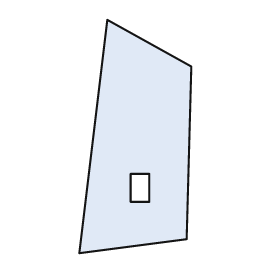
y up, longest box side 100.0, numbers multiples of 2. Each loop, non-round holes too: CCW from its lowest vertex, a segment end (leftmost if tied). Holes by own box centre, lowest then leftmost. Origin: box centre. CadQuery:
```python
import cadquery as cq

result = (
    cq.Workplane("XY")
    .moveTo(-24.0, -50.0)
    .lineTo(22.0, -44.0)
    .lineTo(24.0, 30.0)
    .lineTo(-12.0, 50.0)
    .close()
    .moveTo(-2.0, -28.0)
    .lineTo(6.0, -28.0)
    .lineTo(6.0, -16.0)
    .lineTo(-2.0, -16.0)
    .close()
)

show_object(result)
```